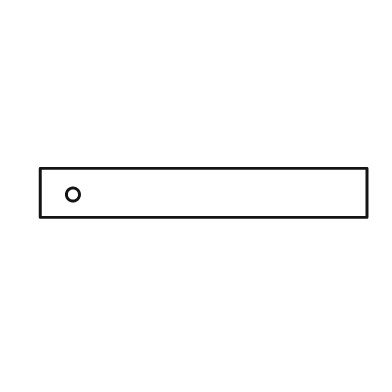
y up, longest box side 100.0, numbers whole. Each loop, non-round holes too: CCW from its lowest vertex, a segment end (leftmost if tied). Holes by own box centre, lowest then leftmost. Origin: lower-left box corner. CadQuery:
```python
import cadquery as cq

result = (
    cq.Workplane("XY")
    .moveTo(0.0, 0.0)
    .lineTo(100.0, 0.0)
    .lineTo(100.0, 15.0)
    .lineTo(0.0, 15.0)
    .close()
    .moveTo(10.0, 7.0)
    .circle(2.0)
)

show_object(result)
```